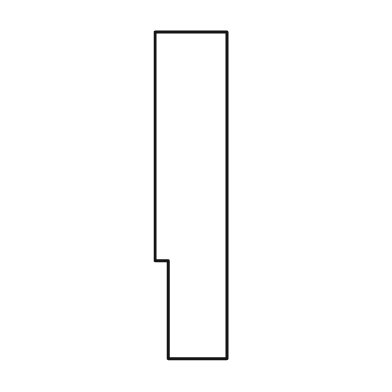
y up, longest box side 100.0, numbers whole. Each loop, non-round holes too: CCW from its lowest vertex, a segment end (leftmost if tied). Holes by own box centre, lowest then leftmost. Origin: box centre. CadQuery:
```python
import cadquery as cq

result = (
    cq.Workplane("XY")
    .moveTo(-7.0, -50.0)
    .lineTo(11.0, -50.0)
    .lineTo(11.0, 50.0)
    .lineTo(-11.0, 50.0)
    .lineTo(-11.0, -20.0)
    .lineTo(-7.0, -20.0)
    .close()
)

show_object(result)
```